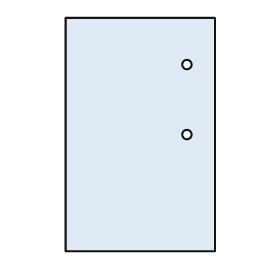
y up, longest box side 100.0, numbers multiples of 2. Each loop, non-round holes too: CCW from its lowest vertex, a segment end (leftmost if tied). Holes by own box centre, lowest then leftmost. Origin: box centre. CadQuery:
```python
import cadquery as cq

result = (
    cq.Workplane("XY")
    .moveTo(-32.0, -50.0)
    .lineTo(32.0, -50.0)
    .lineTo(32.0, 50.0)
    .lineTo(-32.0, 50.0)
    .close()
    .moveTo(20.0, 0.0)
    .circle(2.0)
    .moveTo(20.0, 30.0)
    .circle(2.0)
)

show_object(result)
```